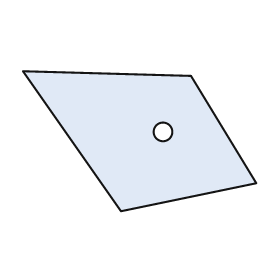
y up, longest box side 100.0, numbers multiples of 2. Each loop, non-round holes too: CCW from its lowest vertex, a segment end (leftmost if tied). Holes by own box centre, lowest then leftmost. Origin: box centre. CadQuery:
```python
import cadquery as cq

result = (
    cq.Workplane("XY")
    .moveTo(-8.0, -30.0)
    .lineTo(50.0, -18.0)
    .lineTo(22.0, 28.0)
    .lineTo(-50.0, 30.0)
    .close()
    .moveTo(10.0, 4.0)
    .circle(4.0)
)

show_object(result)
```